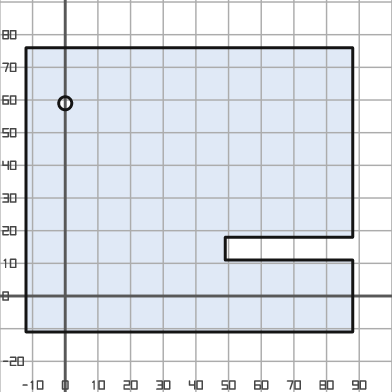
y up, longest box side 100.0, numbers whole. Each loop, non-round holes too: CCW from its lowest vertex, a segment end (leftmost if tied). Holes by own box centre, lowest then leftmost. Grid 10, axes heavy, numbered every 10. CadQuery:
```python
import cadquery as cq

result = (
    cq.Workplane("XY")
    .moveTo(-12.0, -11.0)
    .lineTo(88.0, -11.0)
    .lineTo(88.0, 11.0)
    .lineTo(49.0, 11.0)
    .lineTo(49.0, 18.0)
    .lineTo(88.0, 18.0)
    .lineTo(88.0, 76.0)
    .lineTo(-12.0, 76.0)
    .close()
    .moveTo(0.0, 59.0)
    .circle(2.0)
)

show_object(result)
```